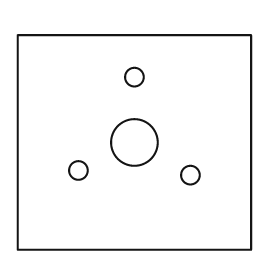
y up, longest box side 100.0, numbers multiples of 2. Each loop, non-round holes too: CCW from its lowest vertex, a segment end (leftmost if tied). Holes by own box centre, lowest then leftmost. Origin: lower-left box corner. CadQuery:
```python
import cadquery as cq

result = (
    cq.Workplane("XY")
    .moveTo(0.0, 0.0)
    .lineTo(100.0, 0.0)
    .lineTo(100.0, 92.0)
    .lineTo(0.0, 92.0)
    .close()
    .moveTo(74.0, 32.0)
    .circle(4.0)
    .moveTo(26.0, 34.0)
    .circle(4.0)
    .moveTo(50.0, 46.0)
    .circle(10.0)
    .moveTo(50.0, 74.0)
    .circle(4.0)
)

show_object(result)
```